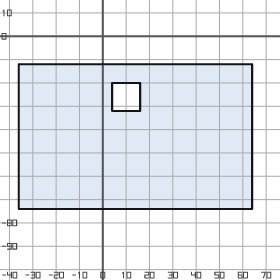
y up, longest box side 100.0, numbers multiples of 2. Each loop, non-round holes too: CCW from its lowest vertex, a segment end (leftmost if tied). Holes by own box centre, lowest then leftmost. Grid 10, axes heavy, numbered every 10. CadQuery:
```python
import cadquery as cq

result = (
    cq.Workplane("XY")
    .moveTo(-36.0, -74.0)
    .lineTo(64.0, -74.0)
    .lineTo(64.0, -12.0)
    .lineTo(-36.0, -12.0)
    .close()
    .moveTo(4.0, -32.0)
    .lineTo(16.0, -32.0)
    .lineTo(16.0, -20.0)
    .lineTo(4.0, -20.0)
    .close()
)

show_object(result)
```